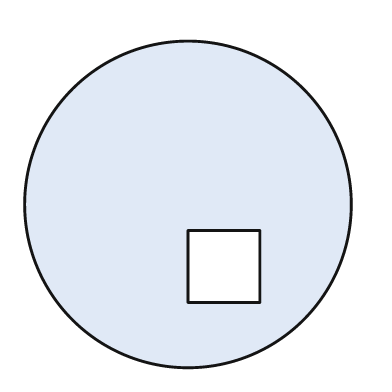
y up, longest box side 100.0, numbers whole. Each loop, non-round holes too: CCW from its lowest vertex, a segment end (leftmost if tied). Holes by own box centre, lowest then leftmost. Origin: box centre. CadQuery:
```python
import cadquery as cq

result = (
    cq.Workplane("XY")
    .moveTo(0.0, 0.0)
    .circle(50.0)
    .moveTo(0.0, -30.0)
    .lineTo(22.0, -30.0)
    .lineTo(22.0, -8.0)
    .lineTo(0.0, -8.0)
    .close()
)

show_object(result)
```